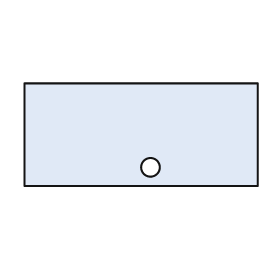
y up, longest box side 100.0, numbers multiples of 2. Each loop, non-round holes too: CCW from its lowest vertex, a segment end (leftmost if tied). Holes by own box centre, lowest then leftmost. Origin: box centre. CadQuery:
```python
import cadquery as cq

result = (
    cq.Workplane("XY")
    .moveTo(-50.0, -22.0)
    .lineTo(50.0, -22.0)
    .lineTo(50.0, 22.0)
    .lineTo(-50.0, 22.0)
    .close()
    .moveTo(4.0, -14.0)
    .circle(4.0)
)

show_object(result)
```